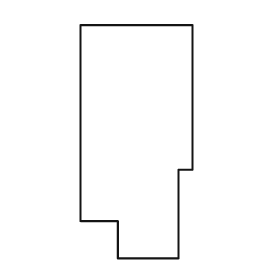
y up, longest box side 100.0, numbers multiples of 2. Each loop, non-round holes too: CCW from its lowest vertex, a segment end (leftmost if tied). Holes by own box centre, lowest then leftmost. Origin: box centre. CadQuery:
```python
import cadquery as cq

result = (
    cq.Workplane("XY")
    .moveTo(-8.0, -50.0)
    .lineTo(18.0, -50.0)
    .lineTo(18.0, -12.0)
    .lineTo(24.0, -12.0)
    .lineTo(24.0, 50.0)
    .lineTo(-24.0, 50.0)
    .lineTo(-24.0, -34.0)
    .lineTo(-8.0, -34.0)
    .close()
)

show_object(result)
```